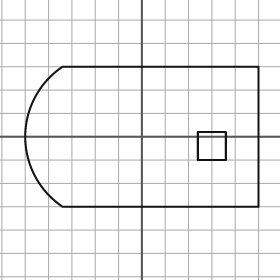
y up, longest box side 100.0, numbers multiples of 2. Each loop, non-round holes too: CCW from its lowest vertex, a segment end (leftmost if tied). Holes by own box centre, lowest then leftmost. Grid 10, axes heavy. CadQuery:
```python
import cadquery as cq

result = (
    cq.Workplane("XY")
    .moveTo(-34.0, -30.0)
    .lineTo(50.0, -30.0)
    .lineTo(50.0, 30.0)
    .lineTo(-34.0, 30.0)
    .threePointArc((-50.0, 0.0), (-34.0, -30.0))
    .close()
    .moveTo(24.0, -10.0)
    .lineTo(36.0, -10.0)
    .lineTo(36.0, 2.0)
    .lineTo(24.0, 2.0)
    .close()
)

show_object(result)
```